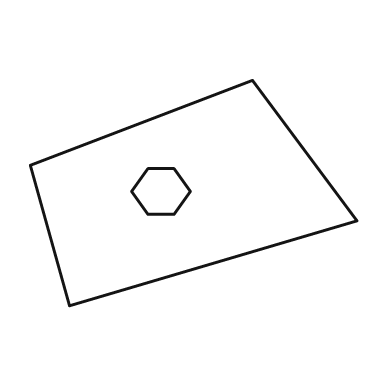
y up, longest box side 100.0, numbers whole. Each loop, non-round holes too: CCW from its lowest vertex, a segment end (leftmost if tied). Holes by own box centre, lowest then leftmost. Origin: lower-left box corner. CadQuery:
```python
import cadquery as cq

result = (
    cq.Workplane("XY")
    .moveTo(12.0, 0.0)
    .lineTo(100.0, 26.0)
    .lineTo(68.0, 69.0)
    .lineTo(0.0, 43.0)
    .close()
    .moveTo(36.0, 28.0)
    .lineTo(44.0, 28.0)
    .lineTo(49.0, 35.0)
    .lineTo(44.0, 42.0)
    .lineTo(36.0, 42.0)
    .lineTo(31.0, 35.0)
    .close()
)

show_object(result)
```